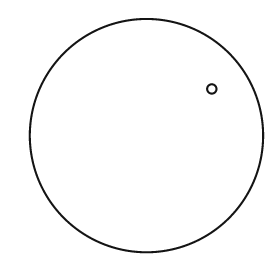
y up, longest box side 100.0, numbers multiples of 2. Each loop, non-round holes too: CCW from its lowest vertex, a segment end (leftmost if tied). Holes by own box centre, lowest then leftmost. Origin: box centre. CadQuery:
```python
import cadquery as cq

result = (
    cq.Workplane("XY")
    .moveTo(0.0, 0.0)
    .circle(50.0)
    .moveTo(28.0, 20.0)
    .circle(2.0)
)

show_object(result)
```